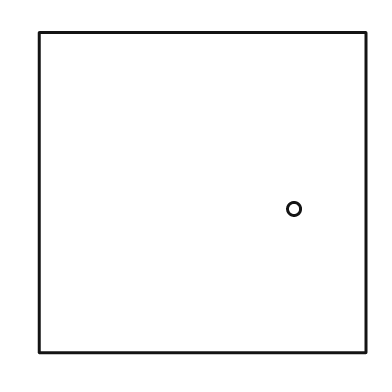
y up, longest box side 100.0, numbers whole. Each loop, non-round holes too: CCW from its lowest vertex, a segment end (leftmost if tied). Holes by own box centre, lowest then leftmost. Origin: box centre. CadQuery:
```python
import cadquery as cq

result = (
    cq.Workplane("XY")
    .moveTo(-50.0, -49.0)
    .lineTo(50.0, -49.0)
    .lineTo(50.0, 49.0)
    .lineTo(-50.0, 49.0)
    .close()
    .moveTo(28.0, -5.0)
    .circle(2.0)
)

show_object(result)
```